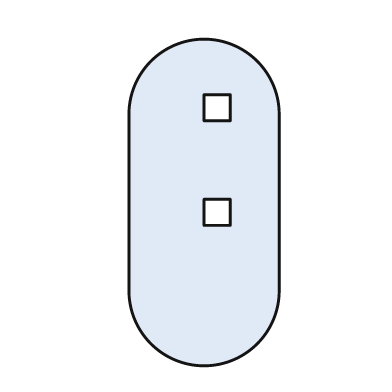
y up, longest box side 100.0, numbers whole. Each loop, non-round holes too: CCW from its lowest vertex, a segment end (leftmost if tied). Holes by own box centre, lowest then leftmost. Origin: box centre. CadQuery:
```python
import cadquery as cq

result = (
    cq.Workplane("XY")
    .moveTo(-23.0, -27.0)
    .threePointArc((0.0, -50.0), (23.0, -27.0))
    .lineTo(23.0, 27.0)
    .threePointArc((0.0, 50.0), (-23.0, 27.0))
    .close()
    .moveTo(0.0, -7.0)
    .lineTo(8.0, -7.0)
    .lineTo(8.0, 1.0)
    .lineTo(0.0, 1.0)
    .close()
    .moveTo(0.0, 25.0)
    .lineTo(8.0, 25.0)
    .lineTo(8.0, 33.0)
    .lineTo(0.0, 33.0)
    .close()
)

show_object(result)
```